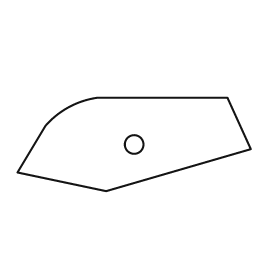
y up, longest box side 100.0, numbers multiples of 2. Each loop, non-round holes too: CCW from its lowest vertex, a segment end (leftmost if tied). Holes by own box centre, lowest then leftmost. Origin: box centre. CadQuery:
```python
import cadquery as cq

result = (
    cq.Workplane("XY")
    .moveTo(-12.0, -20.0)
    .lineTo(50.0, -2.0)
    .lineTo(40.0, 20.0)
    .lineTo(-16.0, 20.0)
    .threePointArc((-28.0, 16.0), (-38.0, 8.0))
    .lineTo(-50.0, -12.0)
    .close()
    .moveTo(0.0, 0.0)
    .circle(4.0)
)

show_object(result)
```